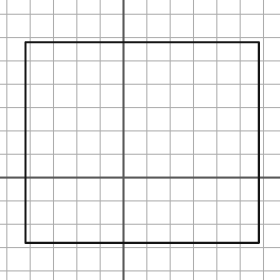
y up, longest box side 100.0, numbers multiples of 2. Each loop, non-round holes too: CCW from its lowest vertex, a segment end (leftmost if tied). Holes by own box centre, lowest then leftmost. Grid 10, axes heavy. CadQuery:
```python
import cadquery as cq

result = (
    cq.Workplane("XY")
    .moveTo(-42.0, -28.0)
    .lineTo(58.0, -28.0)
    .lineTo(58.0, 58.0)
    .lineTo(-42.0, 58.0)
    .close()
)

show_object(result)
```